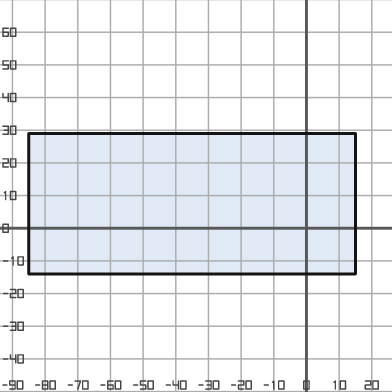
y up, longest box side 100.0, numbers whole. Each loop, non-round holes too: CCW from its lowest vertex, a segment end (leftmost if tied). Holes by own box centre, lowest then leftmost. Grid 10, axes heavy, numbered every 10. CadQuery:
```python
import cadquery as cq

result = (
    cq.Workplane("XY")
    .moveTo(-85.0, -14.0)
    .lineTo(15.0, -14.0)
    .lineTo(15.0, 29.0)
    .lineTo(-85.0, 29.0)
    .close()
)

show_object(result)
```